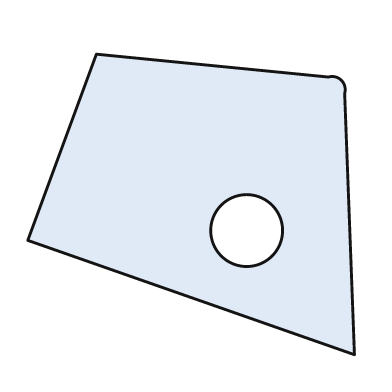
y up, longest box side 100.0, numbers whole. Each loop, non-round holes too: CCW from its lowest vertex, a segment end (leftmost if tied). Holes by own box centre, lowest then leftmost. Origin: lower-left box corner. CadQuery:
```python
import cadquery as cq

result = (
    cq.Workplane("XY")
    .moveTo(100.0, 0.0)
    .lineTo(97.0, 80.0)
    .threePointArc((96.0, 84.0), (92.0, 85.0))
    .lineTo(21.0, 92.0)
    .lineTo(0.0, 35.0)
    .close()
    .moveTo(67.0, 38.0)
    .circle(11.0)
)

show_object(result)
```